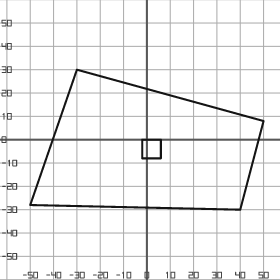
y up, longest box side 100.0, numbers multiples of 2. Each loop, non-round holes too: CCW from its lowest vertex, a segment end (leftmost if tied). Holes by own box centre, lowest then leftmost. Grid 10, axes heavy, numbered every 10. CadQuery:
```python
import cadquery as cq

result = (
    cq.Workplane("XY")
    .moveTo(40.0, -30.0)
    .lineTo(50.0, 8.0)
    .lineTo(-30.0, 30.0)
    .lineTo(-50.0, -28.0)
    .close()
    .moveTo(-2.0, -8.0)
    .lineTo(6.0, -8.0)
    .lineTo(6.0, 0.0)
    .lineTo(-2.0, 0.0)
    .close()
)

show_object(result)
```